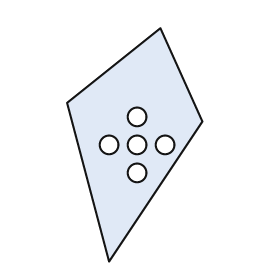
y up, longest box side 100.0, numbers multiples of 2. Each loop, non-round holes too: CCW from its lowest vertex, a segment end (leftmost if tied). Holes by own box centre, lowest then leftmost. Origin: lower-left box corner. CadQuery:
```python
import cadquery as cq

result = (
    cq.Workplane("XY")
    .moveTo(18.0, 0.0)
    .lineTo(58.0, 60.0)
    .lineTo(40.0, 100.0)
    .lineTo(0.0, 68.0)
    .close()
    .moveTo(30.0, 38.0)
    .circle(4.0)
    .moveTo(18.0, 50.0)
    .circle(4.0)
    .moveTo(30.0, 50.0)
    .circle(4.0)
    .moveTo(42.0, 50.0)
    .circle(4.0)
    .moveTo(30.0, 62.0)
    .circle(4.0)
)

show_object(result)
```